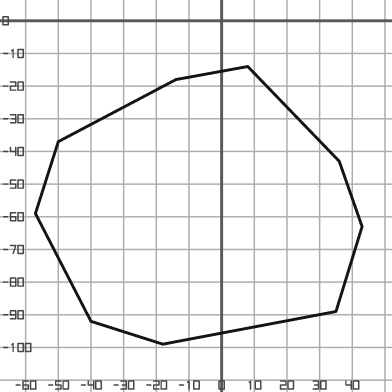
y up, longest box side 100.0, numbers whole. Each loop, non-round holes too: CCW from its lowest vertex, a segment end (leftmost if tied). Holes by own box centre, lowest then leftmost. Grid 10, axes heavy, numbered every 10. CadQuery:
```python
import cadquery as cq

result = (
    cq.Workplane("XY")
    .moveTo(-18.0, -99.0)
    .lineTo(35.0, -89.0)
    .lineTo(43.0, -63.0)
    .lineTo(36.0, -43.0)
    .lineTo(8.0, -14.0)
    .lineTo(-14.0, -18.0)
    .lineTo(-50.0, -37.0)
    .lineTo(-57.0, -59.0)
    .lineTo(-40.0, -92.0)
    .close()
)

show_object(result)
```